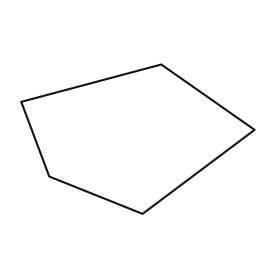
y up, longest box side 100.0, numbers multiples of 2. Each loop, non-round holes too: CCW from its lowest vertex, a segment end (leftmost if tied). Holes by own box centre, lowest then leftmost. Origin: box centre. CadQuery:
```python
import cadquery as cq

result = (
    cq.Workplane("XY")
    .moveTo(2.0, -32.0)
    .lineTo(50.0, 4.0)
    .lineTo(10.0, 32.0)
    .lineTo(-50.0, 16.0)
    .lineTo(-38.0, -16.0)
    .close()
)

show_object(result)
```